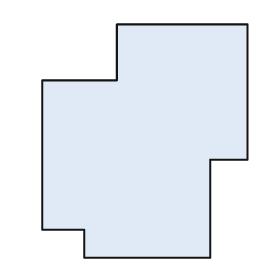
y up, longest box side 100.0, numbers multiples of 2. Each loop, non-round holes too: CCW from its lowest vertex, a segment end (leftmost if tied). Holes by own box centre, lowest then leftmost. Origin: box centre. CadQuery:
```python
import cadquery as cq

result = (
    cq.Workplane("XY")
    .moveTo(-26.0, -50.0)
    .lineTo(28.0, -50.0)
    .lineTo(28.0, -8.0)
    .lineTo(44.0, -8.0)
    .lineTo(44.0, 50.0)
    .lineTo(-12.0, 50.0)
    .lineTo(-12.0, 26.0)
    .lineTo(-44.0, 26.0)
    .lineTo(-44.0, -38.0)
    .lineTo(-26.0, -38.0)
    .close()
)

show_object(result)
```